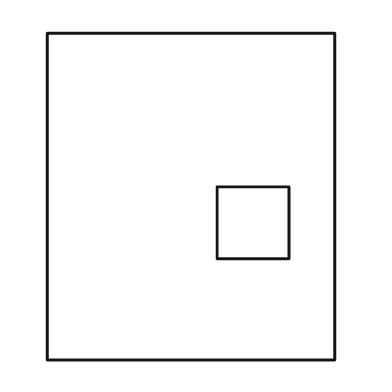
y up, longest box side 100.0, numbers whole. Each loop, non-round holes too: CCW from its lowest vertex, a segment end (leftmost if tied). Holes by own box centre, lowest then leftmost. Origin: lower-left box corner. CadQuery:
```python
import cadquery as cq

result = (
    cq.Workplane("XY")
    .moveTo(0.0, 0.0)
    .lineTo(88.0, 0.0)
    .lineTo(88.0, 100.0)
    .lineTo(0.0, 100.0)
    .close()
    .moveTo(52.0, 31.0)
    .lineTo(74.0, 31.0)
    .lineTo(74.0, 53.0)
    .lineTo(52.0, 53.0)
    .close()
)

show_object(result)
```